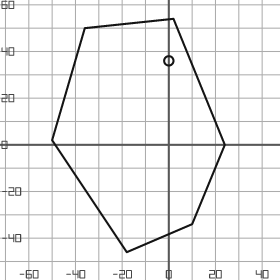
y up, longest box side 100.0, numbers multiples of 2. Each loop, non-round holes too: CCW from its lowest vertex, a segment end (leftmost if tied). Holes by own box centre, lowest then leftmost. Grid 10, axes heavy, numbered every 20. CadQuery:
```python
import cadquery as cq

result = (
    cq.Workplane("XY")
    .moveTo(-18.0, -46.0)
    .lineTo(10.0, -34.0)
    .lineTo(24.0, 0.0)
    .lineTo(2.0, 54.0)
    .lineTo(-36.0, 50.0)
    .lineTo(-50.0, 2.0)
    .close()
    .moveTo(0.0, 36.0)
    .circle(2.0)
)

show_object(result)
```